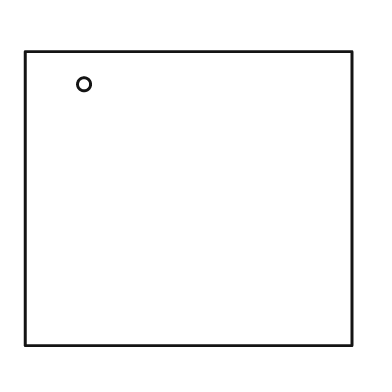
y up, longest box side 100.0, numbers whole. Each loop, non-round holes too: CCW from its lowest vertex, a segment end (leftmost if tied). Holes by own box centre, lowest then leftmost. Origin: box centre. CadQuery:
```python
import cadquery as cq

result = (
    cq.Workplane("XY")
    .moveTo(-50.0, -45.0)
    .lineTo(50.0, -45.0)
    .lineTo(50.0, 45.0)
    .lineTo(-50.0, 45.0)
    .close()
    .moveTo(-32.0, 35.0)
    .circle(2.0)
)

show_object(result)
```